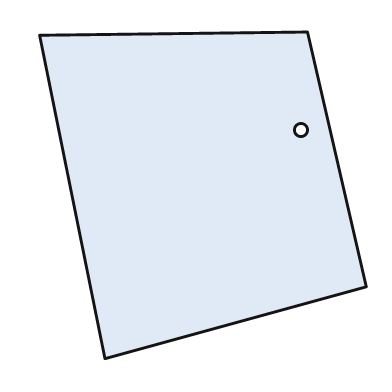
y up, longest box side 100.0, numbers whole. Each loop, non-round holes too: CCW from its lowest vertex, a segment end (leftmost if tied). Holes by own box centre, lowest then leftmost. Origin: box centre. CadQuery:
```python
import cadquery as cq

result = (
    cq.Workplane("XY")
    .moveTo(-30.0, -50.0)
    .lineTo(50.0, -28.0)
    .lineTo(32.0, 50.0)
    .lineTo(-50.0, 49.0)
    .close()
    .moveTo(30.0, 20.0)
    .circle(2.0)
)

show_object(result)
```